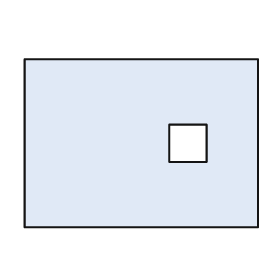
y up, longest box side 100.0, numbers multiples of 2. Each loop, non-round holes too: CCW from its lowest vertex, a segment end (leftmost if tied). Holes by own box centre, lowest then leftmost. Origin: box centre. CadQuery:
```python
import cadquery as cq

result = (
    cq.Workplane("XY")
    .moveTo(-50.0, -36.0)
    .lineTo(50.0, -36.0)
    .lineTo(50.0, 36.0)
    .lineTo(-50.0, 36.0)
    .close()
    .moveTo(12.0, -8.0)
    .lineTo(28.0, -8.0)
    .lineTo(28.0, 8.0)
    .lineTo(12.0, 8.0)
    .close()
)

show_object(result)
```